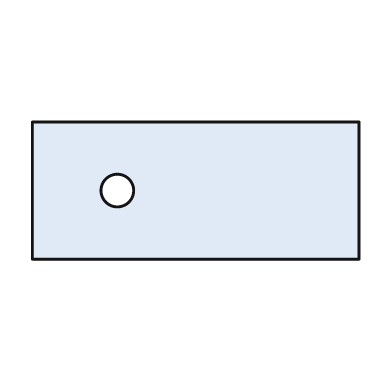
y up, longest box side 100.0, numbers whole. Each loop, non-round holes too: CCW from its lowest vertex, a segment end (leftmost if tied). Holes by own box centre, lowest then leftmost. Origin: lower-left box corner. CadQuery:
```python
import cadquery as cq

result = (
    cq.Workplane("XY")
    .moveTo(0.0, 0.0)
    .lineTo(100.0, 0.0)
    .lineTo(100.0, 42.0)
    .lineTo(0.0, 42.0)
    .close()
    .moveTo(26.0, 21.0)
    .circle(5.0)
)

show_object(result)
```